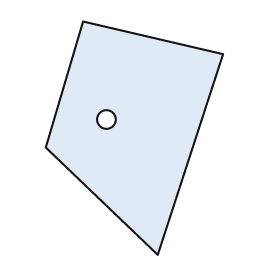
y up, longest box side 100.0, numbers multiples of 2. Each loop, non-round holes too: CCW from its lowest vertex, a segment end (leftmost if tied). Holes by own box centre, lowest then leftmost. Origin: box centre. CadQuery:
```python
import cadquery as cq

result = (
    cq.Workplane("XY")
    .moveTo(10.0, -50.0)
    .lineTo(38.0, 36.0)
    .lineTo(-22.0, 50.0)
    .lineTo(-38.0, -4.0)
    .close()
    .moveTo(-12.0, 8.0)
    .circle(4.0)
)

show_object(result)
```